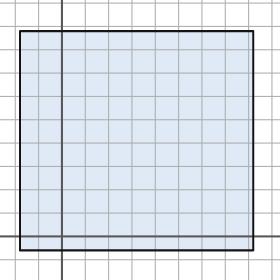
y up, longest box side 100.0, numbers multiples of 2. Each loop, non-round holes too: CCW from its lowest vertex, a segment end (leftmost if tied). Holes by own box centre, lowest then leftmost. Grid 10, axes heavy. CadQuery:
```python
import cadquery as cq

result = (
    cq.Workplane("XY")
    .moveTo(-18.0, -6.0)
    .lineTo(82.0, -6.0)
    .lineTo(82.0, 88.0)
    .lineTo(-18.0, 88.0)
    .close()
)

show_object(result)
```